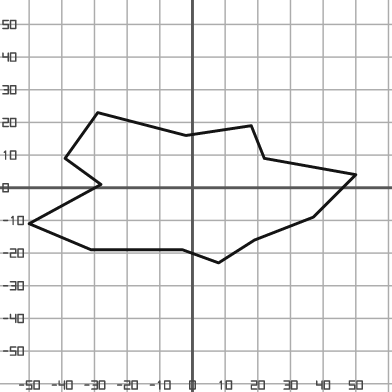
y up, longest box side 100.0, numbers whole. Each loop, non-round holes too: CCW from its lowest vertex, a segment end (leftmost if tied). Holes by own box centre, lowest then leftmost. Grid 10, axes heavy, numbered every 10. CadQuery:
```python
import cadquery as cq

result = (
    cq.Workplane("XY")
    .moveTo(8.0, -23.0)
    .lineTo(19.0, -16.0)
    .lineTo(37.0, -9.0)
    .lineTo(50.0, 4.0)
    .lineTo(22.0, 9.0)
    .lineTo(18.0, 19.0)
    .lineTo(-2.0, 16.0)
    .lineTo(-29.0, 23.0)
    .lineTo(-39.0, 9.0)
    .lineTo(-28.0, 1.0)
    .lineTo(-50.0, -11.0)
    .lineTo(-31.0, -19.0)
    .lineTo(-3.0, -19.0)
    .close()
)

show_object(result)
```